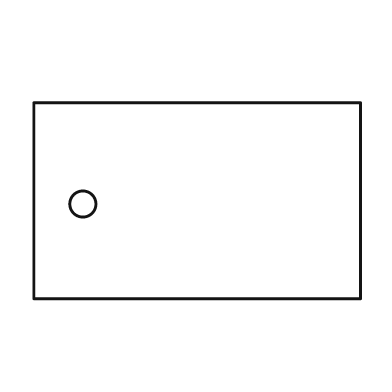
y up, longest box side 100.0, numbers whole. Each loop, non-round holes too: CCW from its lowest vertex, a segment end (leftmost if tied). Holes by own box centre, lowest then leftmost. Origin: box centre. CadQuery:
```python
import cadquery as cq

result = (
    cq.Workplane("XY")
    .moveTo(-50.0, -30.0)
    .lineTo(50.0, -30.0)
    .lineTo(50.0, 30.0)
    .lineTo(-50.0, 30.0)
    .close()
    .moveTo(-35.0, -1.0)
    .circle(4.0)
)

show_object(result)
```